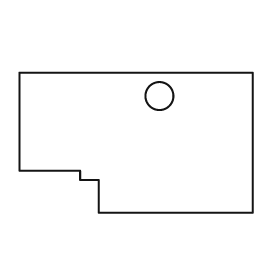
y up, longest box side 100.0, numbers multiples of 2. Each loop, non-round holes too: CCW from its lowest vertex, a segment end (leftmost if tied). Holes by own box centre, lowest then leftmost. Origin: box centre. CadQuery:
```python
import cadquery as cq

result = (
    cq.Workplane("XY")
    .moveTo(-16.0, -30.0)
    .lineTo(50.0, -30.0)
    .lineTo(50.0, 30.0)
    .lineTo(-50.0, 30.0)
    .lineTo(-50.0, -12.0)
    .lineTo(-24.0, -12.0)
    .lineTo(-24.0, -16.0)
    .lineTo(-16.0, -16.0)
    .close()
    .moveTo(10.0, 20.0)
    .circle(6.0)
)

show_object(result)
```